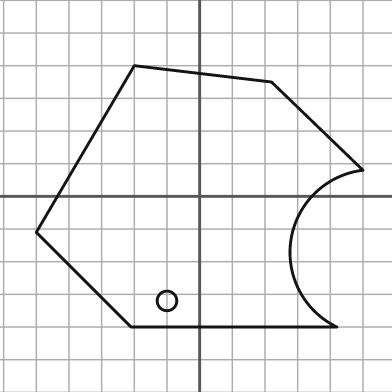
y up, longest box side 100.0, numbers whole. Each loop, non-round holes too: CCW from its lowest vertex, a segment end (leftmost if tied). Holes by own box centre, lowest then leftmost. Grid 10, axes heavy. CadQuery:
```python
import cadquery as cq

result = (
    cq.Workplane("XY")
    .moveTo(-21.0, -40.0)
    .lineTo(42.0, -40.0)
    .threePointArc((28.0, -13.0), (50.0, 8.0))
    .lineTo(22.0, 35.0)
    .lineTo(-20.0, 40.0)
    .lineTo(-50.0, -11.0)
    .close()
    .moveTo(-10.0, -32.0)
    .circle(3.0)
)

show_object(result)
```